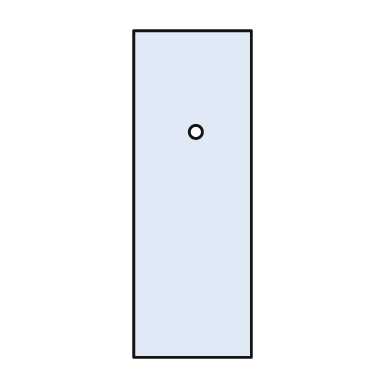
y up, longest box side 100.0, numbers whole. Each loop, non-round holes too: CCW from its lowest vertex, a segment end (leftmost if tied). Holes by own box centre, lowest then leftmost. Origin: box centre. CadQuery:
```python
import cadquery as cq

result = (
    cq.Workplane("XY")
    .moveTo(-18.0, -50.0)
    .lineTo(18.0, -50.0)
    .lineTo(18.0, 50.0)
    .lineTo(-18.0, 50.0)
    .close()
    .moveTo(1.0, 19.0)
    .circle(2.0)
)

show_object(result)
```